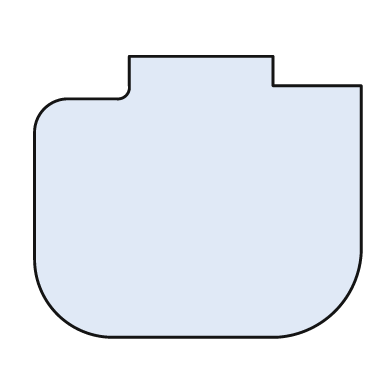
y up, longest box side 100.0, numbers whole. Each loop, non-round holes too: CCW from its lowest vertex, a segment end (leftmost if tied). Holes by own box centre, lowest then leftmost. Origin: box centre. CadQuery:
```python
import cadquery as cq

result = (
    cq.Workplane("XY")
    .moveTo(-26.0, -43.0)
    .lineTo(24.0, -43.0)
    .threePointArc((42.0, -35.0), (50.0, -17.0))
    .lineTo(50.0, 34.0)
    .lineTo(23.0, 34.0)
    .lineTo(23.0, 43.0)
    .lineTo(-21.0, 43.0)
    .lineTo(-21.0, 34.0)
    .threePointArc((-22.0, 31.0), (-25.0, 30.0))
    .lineTo(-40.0, 30.0)
    .threePointArc((-47.0, 27.0), (-50.0, 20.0))
    .lineTo(-50.0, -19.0)
    .threePointArc((-43.0, -36.0), (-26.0, -43.0))
    .close()
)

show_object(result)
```